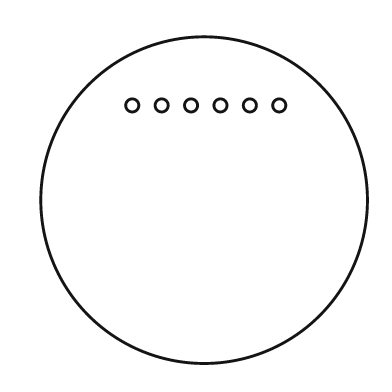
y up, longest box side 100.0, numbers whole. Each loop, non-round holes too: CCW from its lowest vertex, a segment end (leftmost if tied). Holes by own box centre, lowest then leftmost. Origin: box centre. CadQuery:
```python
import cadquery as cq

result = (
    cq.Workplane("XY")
    .moveTo(0.0, 0.0)
    .circle(50.0)
    .moveTo(-22.0, 29.0)
    .circle(2.0)
    .moveTo(-13.0, 29.0)
    .circle(2.0)
    .moveTo(-4.0, 29.0)
    .circle(2.0)
    .moveTo(5.0, 29.0)
    .circle(2.0)
    .moveTo(14.0, 29.0)
    .circle(2.0)
    .moveTo(23.0, 29.0)
    .circle(2.0)
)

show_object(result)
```